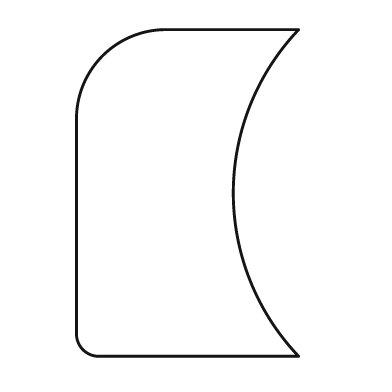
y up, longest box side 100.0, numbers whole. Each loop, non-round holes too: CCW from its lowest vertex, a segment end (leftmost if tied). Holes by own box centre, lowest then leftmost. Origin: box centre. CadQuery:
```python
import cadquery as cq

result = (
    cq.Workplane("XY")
    .moveTo(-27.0, -50.0)
    .lineTo(34.0, -50.0)
    .threePointArc((14.0, 0.0), (34.0, 50.0))
    .lineTo(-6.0, 50.0)
    .threePointArc((-26.0, 42.0), (-34.0, 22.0))
    .lineTo(-34.0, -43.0)
    .threePointArc((-32.0, -48.0), (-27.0, -50.0))
    .close()
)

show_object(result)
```